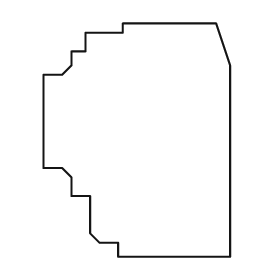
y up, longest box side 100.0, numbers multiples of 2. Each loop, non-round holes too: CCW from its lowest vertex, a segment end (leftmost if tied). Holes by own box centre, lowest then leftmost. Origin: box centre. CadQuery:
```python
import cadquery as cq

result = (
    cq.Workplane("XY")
    .moveTo(-8.0, -50.0)
    .lineTo(40.0, -50.0)
    .lineTo(40.0, 32.0)
    .lineTo(34.0, 50.0)
    .lineTo(-6.0, 50.0)
    .lineTo(-6.0, 46.0)
    .lineTo(-22.0, 46.0)
    .lineTo(-22.0, 38.0)
    .lineTo(-28.0, 38.0)
    .lineTo(-28.0, 32.0)
    .lineTo(-32.0, 28.0)
    .lineTo(-40.0, 28.0)
    .lineTo(-40.0, -12.0)
    .lineTo(-32.0, -12.0)
    .lineTo(-28.0, -16.0)
    .lineTo(-28.0, -24.0)
    .lineTo(-20.0, -24.0)
    .lineTo(-20.0, -40.0)
    .lineTo(-16.0, -44.0)
    .lineTo(-8.0, -44.0)
    .close()
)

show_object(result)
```